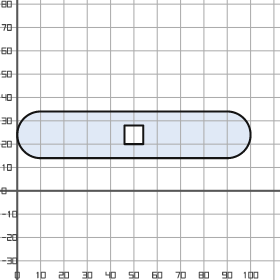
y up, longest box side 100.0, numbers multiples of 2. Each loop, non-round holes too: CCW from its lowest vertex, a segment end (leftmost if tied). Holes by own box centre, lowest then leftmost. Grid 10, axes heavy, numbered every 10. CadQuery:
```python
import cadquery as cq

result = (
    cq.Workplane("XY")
    .moveTo(10.0, 14.0)
    .lineTo(90.0, 14.0)
    .threePointArc((100.0, 24.0), (90.0, 34.0))
    .lineTo(10.0, 34.0)
    .threePointArc((0.0, 24.0), (10.0, 14.0))
    .close()
    .moveTo(46.0, 20.0)
    .lineTo(54.0, 20.0)
    .lineTo(54.0, 28.0)
    .lineTo(46.0, 28.0)
    .close()
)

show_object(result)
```